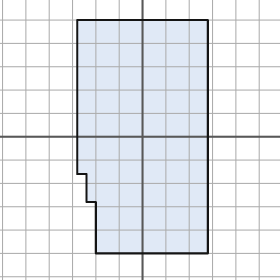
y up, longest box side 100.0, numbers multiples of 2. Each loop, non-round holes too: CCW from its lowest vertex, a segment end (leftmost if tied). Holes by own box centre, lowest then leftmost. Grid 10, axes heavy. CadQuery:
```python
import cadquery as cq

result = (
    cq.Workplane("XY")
    .moveTo(-20.0, -50.0)
    .lineTo(28.0, -50.0)
    .lineTo(28.0, 50.0)
    .lineTo(-28.0, 50.0)
    .lineTo(-28.0, -16.0)
    .lineTo(-24.0, -16.0)
    .lineTo(-24.0, -28.0)
    .lineTo(-20.0, -28.0)
    .close()
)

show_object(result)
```